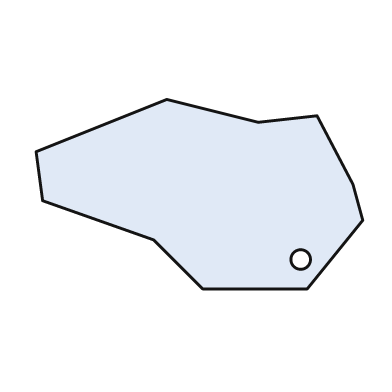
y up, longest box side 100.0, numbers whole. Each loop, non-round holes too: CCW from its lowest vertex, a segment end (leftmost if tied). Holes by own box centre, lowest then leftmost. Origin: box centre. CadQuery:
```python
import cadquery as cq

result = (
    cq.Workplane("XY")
    .moveTo(1.0, -29.0)
    .lineTo(33.0, -29.0)
    .lineTo(50.0, -8.0)
    .lineTo(47.0, 3.0)
    .lineTo(36.0, 24.0)
    .lineTo(18.0, 22.0)
    .lineTo(-10.0, 29.0)
    .lineTo(-50.0, 13.0)
    .lineTo(-48.0, -2.0)
    .lineTo(-14.0, -14.0)
    .close()
    .moveTo(31.0, -20.0)
    .circle(3.0)
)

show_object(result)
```